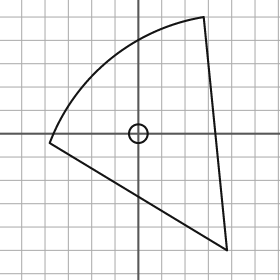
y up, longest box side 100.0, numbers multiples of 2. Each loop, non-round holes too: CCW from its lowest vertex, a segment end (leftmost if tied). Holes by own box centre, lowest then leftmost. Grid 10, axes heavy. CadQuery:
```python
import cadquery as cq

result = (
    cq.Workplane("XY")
    .moveTo(38.0, -50.0)
    .lineTo(28.0, 50.0)
    .threePointArc((-12.0, 32.0), (-38.0, -4.0))
    .close()
    .moveTo(0.0, 0.0)
    .circle(4.0)
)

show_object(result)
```